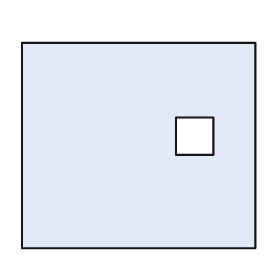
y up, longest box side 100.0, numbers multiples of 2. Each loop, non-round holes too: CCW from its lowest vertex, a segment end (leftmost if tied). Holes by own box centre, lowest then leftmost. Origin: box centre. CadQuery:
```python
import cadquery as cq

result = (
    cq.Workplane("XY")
    .moveTo(-50.0, -44.0)
    .lineTo(50.0, -44.0)
    .lineTo(50.0, 44.0)
    .lineTo(-50.0, 44.0)
    .close()
    .moveTo(16.0, -4.0)
    .lineTo(32.0, -4.0)
    .lineTo(32.0, 12.0)
    .lineTo(16.0, 12.0)
    .close()
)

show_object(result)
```